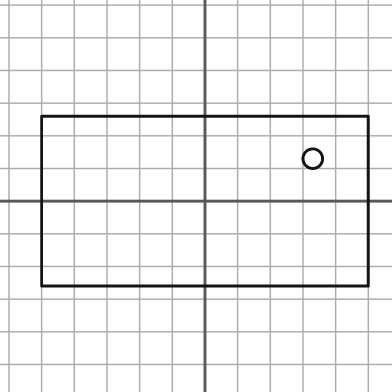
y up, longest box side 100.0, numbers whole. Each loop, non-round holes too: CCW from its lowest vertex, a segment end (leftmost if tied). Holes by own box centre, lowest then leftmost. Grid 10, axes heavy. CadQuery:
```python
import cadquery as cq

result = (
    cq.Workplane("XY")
    .moveTo(-50.0, -26.0)
    .lineTo(50.0, -26.0)
    .lineTo(50.0, 26.0)
    .lineTo(-50.0, 26.0)
    .close()
    .moveTo(33.0, 13.0)
    .circle(3.0)
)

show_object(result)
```